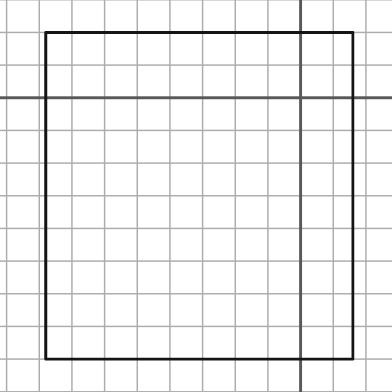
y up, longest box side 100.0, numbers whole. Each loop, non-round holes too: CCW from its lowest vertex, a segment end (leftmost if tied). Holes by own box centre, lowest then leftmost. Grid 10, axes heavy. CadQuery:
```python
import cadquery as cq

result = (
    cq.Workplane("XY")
    .moveTo(-78.0, -80.0)
    .lineTo(16.0, -80.0)
    .lineTo(16.0, 20.0)
    .lineTo(-78.0, 20.0)
    .close()
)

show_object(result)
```